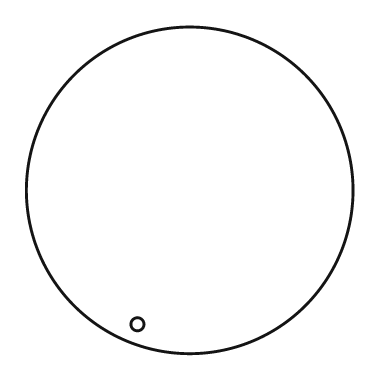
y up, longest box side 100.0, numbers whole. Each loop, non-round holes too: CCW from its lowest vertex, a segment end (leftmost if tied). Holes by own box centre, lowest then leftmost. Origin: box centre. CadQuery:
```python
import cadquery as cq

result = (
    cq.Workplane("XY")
    .moveTo(0.0, 0.0)
    .circle(50.0)
    .moveTo(-16.0, -41.0)
    .circle(2.0)
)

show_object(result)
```